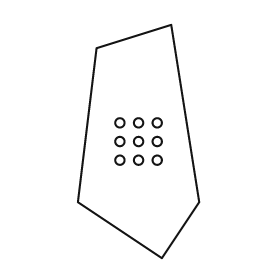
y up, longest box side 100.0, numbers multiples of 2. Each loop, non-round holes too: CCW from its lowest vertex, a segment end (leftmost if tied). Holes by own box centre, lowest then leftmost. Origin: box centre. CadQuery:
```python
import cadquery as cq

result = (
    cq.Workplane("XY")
    .moveTo(10.0, -50.0)
    .lineTo(26.0, -26.0)
    .lineTo(14.0, 50.0)
    .lineTo(-18.0, 40.0)
    .lineTo(-26.0, -26.0)
    .close()
    .moveTo(-8.0, -8.0)
    .circle(2.0)
    .moveTo(0.0, -8.0)
    .circle(2.0)
    .moveTo(8.0, -8.0)
    .circle(2.0)
    .moveTo(-8.0, 0.0)
    .circle(2.0)
    .moveTo(0.0, 0.0)
    .circle(2.0)
    .moveTo(8.0, 0.0)
    .circle(2.0)
    .moveTo(-8.0, 8.0)
    .circle(2.0)
    .moveTo(0.0, 8.0)
    .circle(2.0)
    .moveTo(8.0, 8.0)
    .circle(2.0)
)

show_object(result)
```